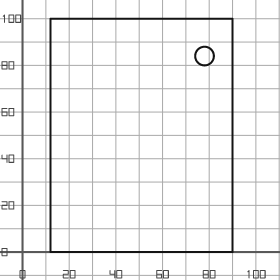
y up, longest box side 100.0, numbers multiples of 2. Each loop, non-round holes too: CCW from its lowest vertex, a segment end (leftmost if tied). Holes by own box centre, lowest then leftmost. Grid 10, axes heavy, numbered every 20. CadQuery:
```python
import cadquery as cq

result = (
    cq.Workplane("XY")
    .moveTo(12.0, 0.0)
    .lineTo(90.0, 0.0)
    .lineTo(90.0, 100.0)
    .lineTo(12.0, 100.0)
    .close()
    .moveTo(78.0, 84.0)
    .circle(4.0)
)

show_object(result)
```